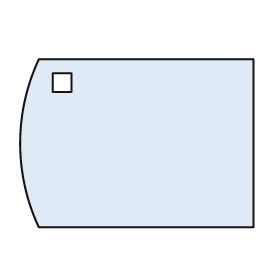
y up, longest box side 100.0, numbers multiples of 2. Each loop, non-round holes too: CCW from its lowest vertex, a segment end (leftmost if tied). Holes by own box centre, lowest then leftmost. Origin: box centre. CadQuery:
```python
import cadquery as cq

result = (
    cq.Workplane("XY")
    .moveTo(-42.0, -36.0)
    .lineTo(50.0, -36.0)
    .lineTo(50.0, 36.0)
    .lineTo(-42.0, 36.0)
    .threePointArc((-50.0, 0.0), (-42.0, -36.0))
    .close()
    .moveTo(-36.0, 22.0)
    .lineTo(-28.0, 22.0)
    .lineTo(-28.0, 30.0)
    .lineTo(-36.0, 30.0)
    .close()
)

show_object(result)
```